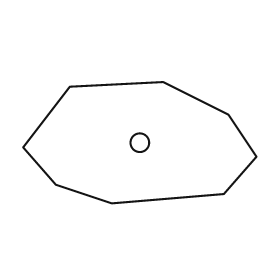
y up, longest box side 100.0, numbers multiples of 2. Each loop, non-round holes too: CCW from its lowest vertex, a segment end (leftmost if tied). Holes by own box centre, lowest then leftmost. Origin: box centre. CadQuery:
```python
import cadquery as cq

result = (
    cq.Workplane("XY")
    .moveTo(-12.0, -26.0)
    .lineTo(36.0, -22.0)
    .lineTo(50.0, -6.0)
    .lineTo(38.0, 12.0)
    .lineTo(10.0, 26.0)
    .lineTo(-30.0, 24.0)
    .lineTo(-50.0, -2.0)
    .lineTo(-36.0, -18.0)
    .close()
    .moveTo(0.0, 0.0)
    .circle(4.0)
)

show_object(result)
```